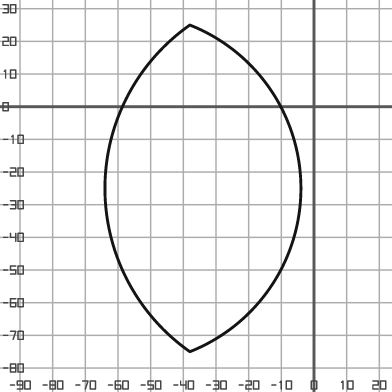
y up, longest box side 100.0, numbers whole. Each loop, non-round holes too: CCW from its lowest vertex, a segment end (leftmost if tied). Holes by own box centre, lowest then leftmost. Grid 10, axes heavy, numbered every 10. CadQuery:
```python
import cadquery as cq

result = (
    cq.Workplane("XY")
    .moveTo(-38.0, -75.0)
    .threePointArc((-4.0, -25.0), (-38.0, 25.0))
    .threePointArc((-64.0, -25.0), (-38.0, -75.0))
    .close()
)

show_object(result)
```